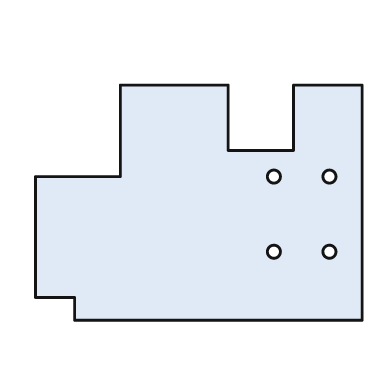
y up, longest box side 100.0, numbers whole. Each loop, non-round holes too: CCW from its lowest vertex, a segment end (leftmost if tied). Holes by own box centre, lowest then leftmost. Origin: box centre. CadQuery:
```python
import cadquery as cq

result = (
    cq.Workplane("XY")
    .moveTo(-38.0, -36.0)
    .lineTo(50.0, -36.0)
    .lineTo(50.0, 36.0)
    .lineTo(29.0, 36.0)
    .lineTo(29.0, 16.0)
    .lineTo(9.0, 16.0)
    .lineTo(9.0, 36.0)
    .lineTo(-24.0, 36.0)
    .lineTo(-24.0, 8.0)
    .lineTo(-50.0, 8.0)
    .lineTo(-50.0, -29.0)
    .lineTo(-38.0, -29.0)
    .close()
    .moveTo(23.0, -15.0)
    .circle(2.0)
    .moveTo(40.0, -15.0)
    .circle(2.0)
    .moveTo(23.0, 8.0)
    .circle(2.0)
    .moveTo(40.0, 8.0)
    .circle(2.0)
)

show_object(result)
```